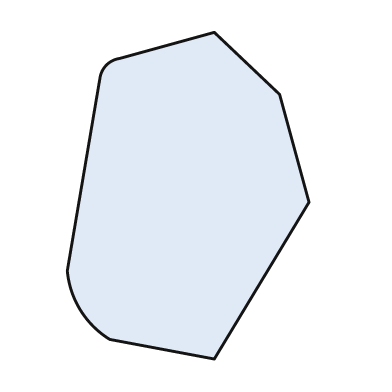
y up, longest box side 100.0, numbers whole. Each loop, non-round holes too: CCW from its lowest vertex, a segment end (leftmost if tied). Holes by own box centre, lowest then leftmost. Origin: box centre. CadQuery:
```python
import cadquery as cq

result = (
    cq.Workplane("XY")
    .moveTo(8.0, -50.0)
    .lineTo(37.0, -2.0)
    .lineTo(28.0, 31.0)
    .lineTo(8.0, 50.0)
    .lineTo(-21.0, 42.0)
    .threePointArc((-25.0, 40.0), (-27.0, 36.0))
    .lineTo(-37.0, -23.0)
    .threePointArc((-33.0, -35.0), (-24.0, -44.0))
    .close()
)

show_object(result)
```